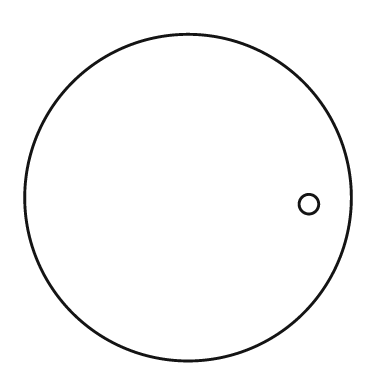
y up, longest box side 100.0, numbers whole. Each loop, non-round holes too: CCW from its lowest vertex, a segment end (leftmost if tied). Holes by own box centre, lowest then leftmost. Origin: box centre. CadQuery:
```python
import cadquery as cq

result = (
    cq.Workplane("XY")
    .moveTo(0.0, 0.0)
    .circle(50.0)
    .moveTo(37.0, -2.0)
    .circle(3.0)
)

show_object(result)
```